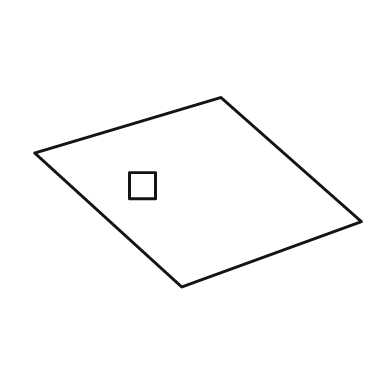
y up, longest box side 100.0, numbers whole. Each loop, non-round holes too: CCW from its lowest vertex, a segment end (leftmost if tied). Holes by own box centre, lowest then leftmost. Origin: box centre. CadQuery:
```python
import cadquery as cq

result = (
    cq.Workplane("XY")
    .moveTo(-5.0, -29.0)
    .lineTo(50.0, -9.0)
    .lineTo(7.0, 29.0)
    .lineTo(-50.0, 12.0)
    .close()
    .moveTo(-21.0, -2.0)
    .lineTo(-13.0, -2.0)
    .lineTo(-13.0, 6.0)
    .lineTo(-21.0, 6.0)
    .close()
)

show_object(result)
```